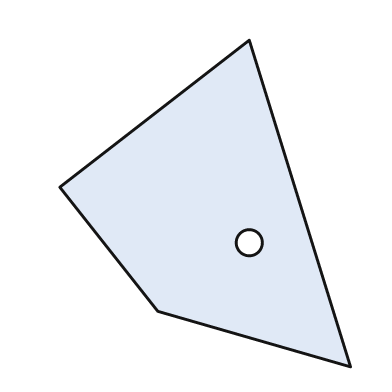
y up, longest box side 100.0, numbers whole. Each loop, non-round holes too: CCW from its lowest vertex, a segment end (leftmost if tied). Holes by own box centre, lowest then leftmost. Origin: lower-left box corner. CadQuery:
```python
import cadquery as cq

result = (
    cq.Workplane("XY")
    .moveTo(89.0, 0.0)
    .lineTo(58.0, 100.0)
    .lineTo(0.0, 55.0)
    .lineTo(30.0, 17.0)
    .close()
    .moveTo(58.0, 38.0)
    .circle(4.0)
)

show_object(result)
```